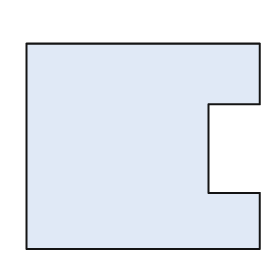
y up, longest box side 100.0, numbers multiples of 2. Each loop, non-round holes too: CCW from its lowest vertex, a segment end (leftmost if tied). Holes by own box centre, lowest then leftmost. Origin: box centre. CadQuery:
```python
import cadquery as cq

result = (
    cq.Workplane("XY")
    .moveTo(-50.0, -44.0)
    .lineTo(50.0, -44.0)
    .lineTo(50.0, -20.0)
    .lineTo(28.0, -20.0)
    .lineTo(28.0, 18.0)
    .lineTo(50.0, 18.0)
    .lineTo(50.0, 44.0)
    .lineTo(-50.0, 44.0)
    .close()
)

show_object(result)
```